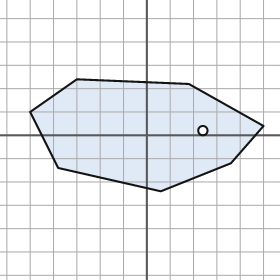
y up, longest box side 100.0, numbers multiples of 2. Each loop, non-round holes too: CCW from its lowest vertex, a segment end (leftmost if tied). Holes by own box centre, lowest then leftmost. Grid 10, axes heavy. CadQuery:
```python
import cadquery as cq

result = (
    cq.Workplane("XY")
    .moveTo(6.0, -24.0)
    .lineTo(36.0, -12.0)
    .lineTo(50.0, 4.0)
    .lineTo(18.0, 22.0)
    .lineTo(-30.0, 24.0)
    .lineTo(-50.0, 10.0)
    .lineTo(-38.0, -14.0)
    .close()
    .moveTo(24.0, 2.0)
    .circle(2.0)
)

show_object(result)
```